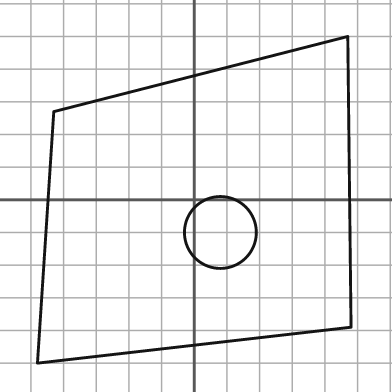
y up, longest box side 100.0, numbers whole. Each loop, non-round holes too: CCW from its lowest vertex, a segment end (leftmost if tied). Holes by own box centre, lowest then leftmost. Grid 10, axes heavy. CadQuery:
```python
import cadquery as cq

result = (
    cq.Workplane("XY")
    .moveTo(-48.0, -50.0)
    .lineTo(48.0, -39.0)
    .lineTo(47.0, 50.0)
    .lineTo(-43.0, 27.0)
    .close()
    .moveTo(8.0, -10.0)
    .circle(11.0)
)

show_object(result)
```